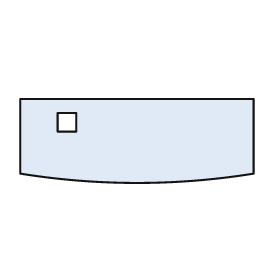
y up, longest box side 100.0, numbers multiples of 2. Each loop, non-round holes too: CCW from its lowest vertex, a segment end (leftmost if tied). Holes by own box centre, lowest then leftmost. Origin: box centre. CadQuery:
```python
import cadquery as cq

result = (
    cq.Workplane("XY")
    .moveTo(-50.0, -14.0)
    .threePointArc((0.0, -18.0), (50.0, -14.0))
    .lineTo(50.0, 18.0)
    .lineTo(-50.0, 18.0)
    .close()
    .moveTo(-34.0, 4.0)
    .lineTo(-26.0, 4.0)
    .lineTo(-26.0, 12.0)
    .lineTo(-34.0, 12.0)
    .close()
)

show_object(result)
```